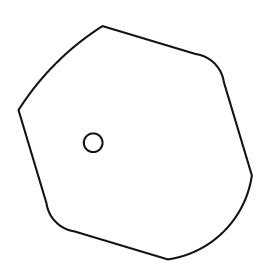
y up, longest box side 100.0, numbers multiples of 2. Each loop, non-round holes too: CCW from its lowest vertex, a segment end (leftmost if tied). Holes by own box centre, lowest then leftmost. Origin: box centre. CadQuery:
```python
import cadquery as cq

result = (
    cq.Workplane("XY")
    .moveTo(14.0, -50.0)
    .threePointArc((38.0, -38.0), (50.0, -14.0))
    .lineTo(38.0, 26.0)
    .threePointArc((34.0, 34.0), (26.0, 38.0))
    .lineTo(-14.0, 50.0)
    .threePointArc((-34.0, 34.0), (-50.0, 14.0))
    .lineTo(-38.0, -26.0)
    .threePointArc((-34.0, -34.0), (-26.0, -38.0))
    .close()
    .moveTo(-18.0, 0.0)
    .circle(4.0)
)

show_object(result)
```